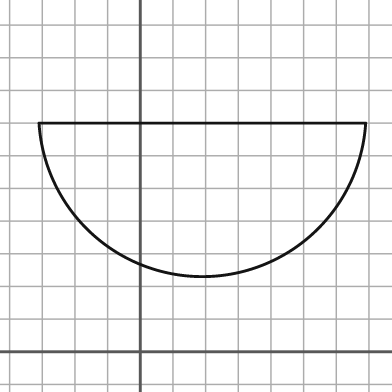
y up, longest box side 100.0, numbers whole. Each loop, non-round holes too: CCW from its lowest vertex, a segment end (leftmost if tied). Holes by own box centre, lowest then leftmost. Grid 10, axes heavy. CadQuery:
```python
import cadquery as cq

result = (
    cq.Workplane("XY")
    .moveTo(-31.0, 70.0)
    .threePointArc((19.0, 23.0), (69.0, 70.0))
    .close()
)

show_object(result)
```